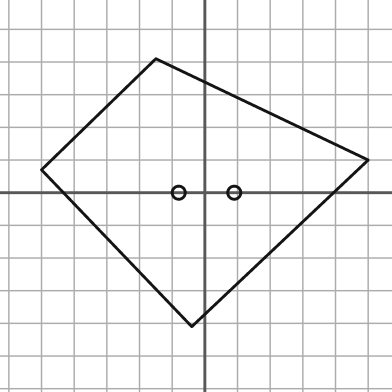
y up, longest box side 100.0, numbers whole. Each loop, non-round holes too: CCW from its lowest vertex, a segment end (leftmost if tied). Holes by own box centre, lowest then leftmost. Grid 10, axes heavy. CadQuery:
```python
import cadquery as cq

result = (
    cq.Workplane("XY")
    .moveTo(-4.0, -41.0)
    .lineTo(50.0, 10.0)
    .lineTo(-15.0, 41.0)
    .lineTo(-50.0, 7.0)
    .close()
    .moveTo(-8.0, 0.0)
    .circle(2.0)
    .moveTo(9.0, 0.0)
    .circle(2.0)
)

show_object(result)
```